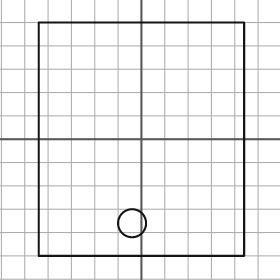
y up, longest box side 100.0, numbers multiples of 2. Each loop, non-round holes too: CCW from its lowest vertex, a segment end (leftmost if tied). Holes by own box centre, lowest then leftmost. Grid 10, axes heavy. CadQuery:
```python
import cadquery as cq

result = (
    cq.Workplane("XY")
    .moveTo(-44.0, -50.0)
    .lineTo(44.0, -50.0)
    .lineTo(44.0, 50.0)
    .lineTo(-44.0, 50.0)
    .close()
    .moveTo(-4.0, -36.0)
    .circle(6.0)
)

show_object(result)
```